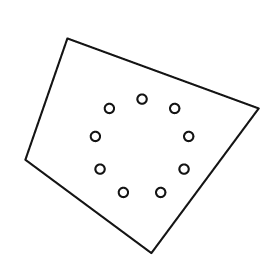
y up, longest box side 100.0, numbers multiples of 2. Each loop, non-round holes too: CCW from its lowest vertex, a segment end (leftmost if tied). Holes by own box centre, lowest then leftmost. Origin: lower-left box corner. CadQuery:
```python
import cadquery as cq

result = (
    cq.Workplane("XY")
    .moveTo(54.0, 0.0)
    .lineTo(100.0, 62.0)
    .lineTo(18.0, 92.0)
    .lineTo(0.0, 40.0)
    .close()
    .moveTo(42.0, 26.0)
    .circle(2.0)
    .moveTo(58.0, 26.0)
    .circle(2.0)
    .moveTo(32.0, 36.0)
    .circle(2.0)
    .moveTo(68.0, 36.0)
    .circle(2.0)
    .moveTo(30.0, 50.0)
    .circle(2.0)
    .moveTo(70.0, 50.0)
    .circle(2.0)
    .moveTo(36.0, 62.0)
    .circle(2.0)
    .moveTo(64.0, 62.0)
    .circle(2.0)
    .moveTo(50.0, 66.0)
    .circle(2.0)
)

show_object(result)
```